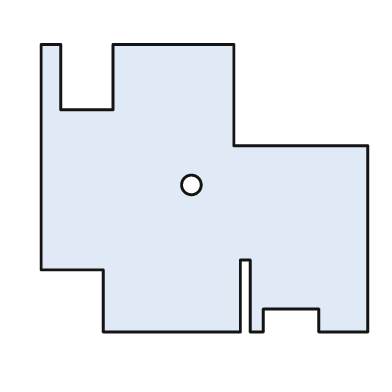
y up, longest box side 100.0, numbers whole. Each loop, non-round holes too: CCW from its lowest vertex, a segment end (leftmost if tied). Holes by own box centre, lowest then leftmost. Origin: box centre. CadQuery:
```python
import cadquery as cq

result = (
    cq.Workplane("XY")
    .moveTo(-31.0, -44.0)
    .lineTo(11.0, -44.0)
    .lineTo(11.0, -22.0)
    .lineTo(14.0, -22.0)
    .lineTo(14.0, -44.0)
    .lineTo(18.0, -44.0)
    .lineTo(18.0, -37.0)
    .lineTo(35.0, -37.0)
    .lineTo(35.0, -44.0)
    .lineTo(50.0, -44.0)
    .lineTo(50.0, 13.0)
    .lineTo(9.0, 13.0)
    .lineTo(9.0, 44.0)
    .lineTo(-28.0, 44.0)
    .lineTo(-28.0, 24.0)
    .lineTo(-44.0, 24.0)
    .lineTo(-44.0, 44.0)
    .lineTo(-50.0, 44.0)
    .lineTo(-50.0, -25.0)
    .lineTo(-31.0, -25.0)
    .close()
    .moveTo(-4.0, 1.0)
    .circle(3.0)
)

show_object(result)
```